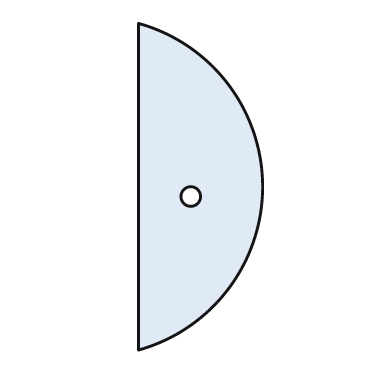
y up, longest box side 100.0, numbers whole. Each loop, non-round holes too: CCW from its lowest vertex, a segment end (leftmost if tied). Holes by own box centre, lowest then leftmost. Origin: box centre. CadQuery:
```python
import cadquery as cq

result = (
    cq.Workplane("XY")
    .moveTo(-19.0, -50.0)
    .threePointArc((19.0, 0.0), (-19.0, 50.0))
    .close()
    .moveTo(-3.0, -3.0)
    .circle(3.0)
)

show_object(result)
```